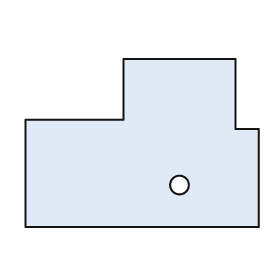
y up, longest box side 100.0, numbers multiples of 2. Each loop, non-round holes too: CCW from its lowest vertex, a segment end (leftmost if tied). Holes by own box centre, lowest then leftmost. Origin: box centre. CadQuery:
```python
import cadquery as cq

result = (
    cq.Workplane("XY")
    .moveTo(-50.0, -36.0)
    .lineTo(50.0, -36.0)
    .lineTo(50.0, 6.0)
    .lineTo(40.0, 6.0)
    .lineTo(40.0, 36.0)
    .lineTo(-8.0, 36.0)
    .lineTo(-8.0, 10.0)
    .lineTo(-50.0, 10.0)
    .close()
    .moveTo(16.0, -18.0)
    .circle(4.0)
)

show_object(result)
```